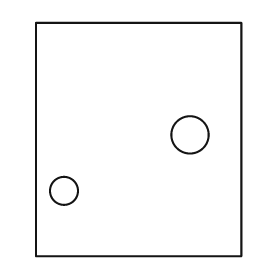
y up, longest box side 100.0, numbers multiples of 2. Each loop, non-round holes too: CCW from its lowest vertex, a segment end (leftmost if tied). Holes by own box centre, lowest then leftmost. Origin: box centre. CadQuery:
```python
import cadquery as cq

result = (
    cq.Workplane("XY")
    .moveTo(-44.0, -50.0)
    .lineTo(44.0, -50.0)
    .lineTo(44.0, 50.0)
    .lineTo(-44.0, 50.0)
    .close()
    .moveTo(-32.0, -22.0)
    .circle(6.0)
    .moveTo(22.0, 2.0)
    .circle(8.0)
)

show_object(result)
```